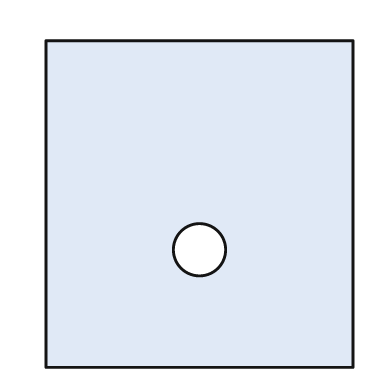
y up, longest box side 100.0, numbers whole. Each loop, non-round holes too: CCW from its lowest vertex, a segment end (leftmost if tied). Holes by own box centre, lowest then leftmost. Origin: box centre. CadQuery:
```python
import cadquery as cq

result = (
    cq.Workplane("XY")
    .moveTo(-47.0, -50.0)
    .lineTo(47.0, -50.0)
    .lineTo(47.0, 50.0)
    .lineTo(-47.0, 50.0)
    .close()
    .moveTo(0.0, -14.0)
    .circle(8.0)
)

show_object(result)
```